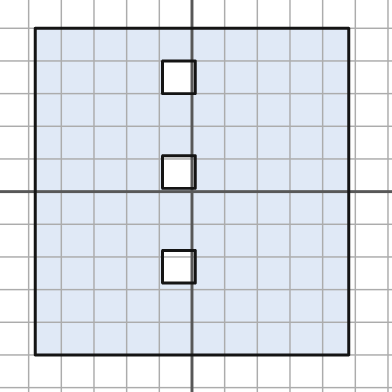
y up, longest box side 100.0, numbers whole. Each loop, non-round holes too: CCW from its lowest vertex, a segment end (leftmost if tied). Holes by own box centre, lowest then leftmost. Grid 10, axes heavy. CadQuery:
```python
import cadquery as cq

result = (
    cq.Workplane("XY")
    .moveTo(-48.0, -50.0)
    .lineTo(48.0, -50.0)
    .lineTo(48.0, 50.0)
    .lineTo(-48.0, 50.0)
    .close()
    .moveTo(-9.0, -28.0)
    .lineTo(1.0, -28.0)
    .lineTo(1.0, -18.0)
    .lineTo(-9.0, -18.0)
    .close()
    .moveTo(-9.0, 1.0)
    .lineTo(1.0, 1.0)
    .lineTo(1.0, 11.0)
    .lineTo(-9.0, 11.0)
    .close()
    .moveTo(-9.0, 30.0)
    .lineTo(1.0, 30.0)
    .lineTo(1.0, 40.0)
    .lineTo(-9.0, 40.0)
    .close()
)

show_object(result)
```